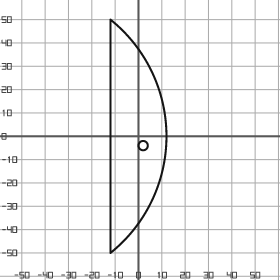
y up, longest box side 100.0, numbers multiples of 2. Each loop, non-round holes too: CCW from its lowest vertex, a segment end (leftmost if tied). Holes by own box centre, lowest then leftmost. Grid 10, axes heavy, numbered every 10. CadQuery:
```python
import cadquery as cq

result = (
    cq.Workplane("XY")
    .moveTo(-12.0, -50.0)
    .threePointArc((12.0, 0.0), (-12.0, 50.0))
    .close()
    .moveTo(2.0, -4.0)
    .circle(2.0)
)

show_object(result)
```